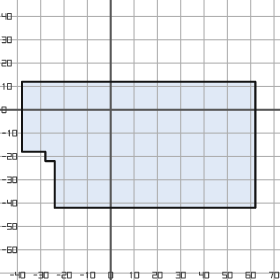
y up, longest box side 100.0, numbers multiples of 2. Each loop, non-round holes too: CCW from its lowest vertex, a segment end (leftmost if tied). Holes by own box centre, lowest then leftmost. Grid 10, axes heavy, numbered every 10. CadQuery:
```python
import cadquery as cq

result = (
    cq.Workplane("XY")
    .moveTo(-24.0, -42.0)
    .lineTo(62.0, -42.0)
    .lineTo(62.0, 12.0)
    .lineTo(-38.0, 12.0)
    .lineTo(-38.0, -18.0)
    .lineTo(-28.0, -18.0)
    .lineTo(-28.0, -22.0)
    .lineTo(-24.0, -22.0)
    .close()
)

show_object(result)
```